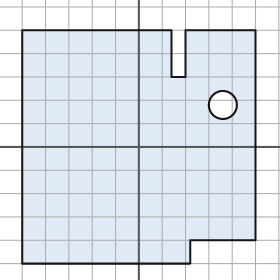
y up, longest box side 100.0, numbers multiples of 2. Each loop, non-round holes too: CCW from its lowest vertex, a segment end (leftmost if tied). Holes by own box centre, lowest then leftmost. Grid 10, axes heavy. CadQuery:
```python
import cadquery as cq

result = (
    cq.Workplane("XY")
    .moveTo(-50.0, -50.0)
    .lineTo(22.0, -50.0)
    .lineTo(22.0, -40.0)
    .lineTo(50.0, -40.0)
    .lineTo(50.0, 50.0)
    .lineTo(20.0, 50.0)
    .lineTo(20.0, 30.0)
    .lineTo(14.0, 30.0)
    .lineTo(14.0, 50.0)
    .lineTo(-50.0, 50.0)
    .close()
    .moveTo(36.0, 18.0)
    .circle(6.0)
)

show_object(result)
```